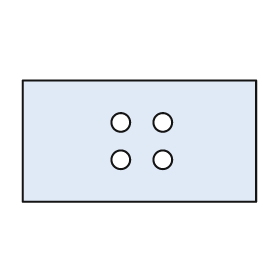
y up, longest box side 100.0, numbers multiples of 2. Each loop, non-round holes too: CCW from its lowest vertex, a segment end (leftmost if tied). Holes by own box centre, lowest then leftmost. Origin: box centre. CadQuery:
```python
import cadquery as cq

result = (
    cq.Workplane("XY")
    .moveTo(-50.0, -26.0)
    .lineTo(50.0, -26.0)
    .lineTo(50.0, 26.0)
    .lineTo(-50.0, 26.0)
    .close()
    .moveTo(-8.0, -8.0)
    .circle(4.0)
    .moveTo(10.0, -8.0)
    .circle(4.0)
    .moveTo(-8.0, 8.0)
    .circle(4.0)
    .moveTo(10.0, 8.0)
    .circle(4.0)
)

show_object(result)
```